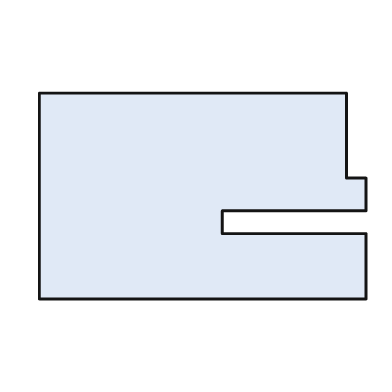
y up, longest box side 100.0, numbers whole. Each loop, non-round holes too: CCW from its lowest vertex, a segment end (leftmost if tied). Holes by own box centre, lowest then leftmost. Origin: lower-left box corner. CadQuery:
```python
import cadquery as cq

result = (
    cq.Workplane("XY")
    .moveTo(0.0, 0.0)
    .lineTo(100.0, 0.0)
    .lineTo(100.0, 20.0)
    .lineTo(56.0, 20.0)
    .lineTo(56.0, 27.0)
    .lineTo(100.0, 27.0)
    .lineTo(100.0, 37.0)
    .lineTo(94.0, 37.0)
    .lineTo(94.0, 63.0)
    .lineTo(0.0, 63.0)
    .close()
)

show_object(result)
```